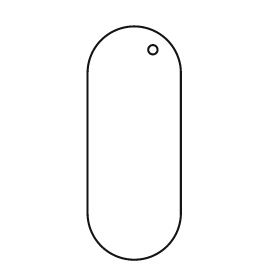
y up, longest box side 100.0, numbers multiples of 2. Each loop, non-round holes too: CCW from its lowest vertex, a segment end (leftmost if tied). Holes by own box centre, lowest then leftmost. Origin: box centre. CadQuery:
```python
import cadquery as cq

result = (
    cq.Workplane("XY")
    .moveTo(-20.0, -30.0)
    .threePointArc((0.0, -50.0), (20.0, -30.0))
    .lineTo(20.0, 30.0)
    .threePointArc((0.0, 50.0), (-20.0, 30.0))
    .close()
    .moveTo(8.0, 40.0)
    .circle(2.0)
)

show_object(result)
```